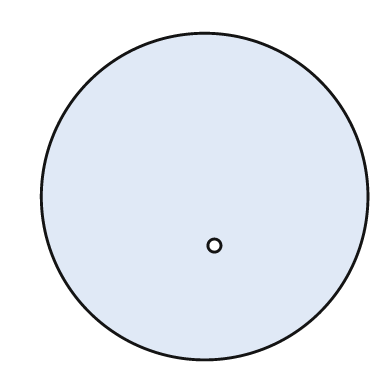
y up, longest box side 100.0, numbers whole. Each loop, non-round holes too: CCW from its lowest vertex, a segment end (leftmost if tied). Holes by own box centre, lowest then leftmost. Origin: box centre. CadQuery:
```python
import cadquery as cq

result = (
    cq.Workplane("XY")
    .moveTo(0.0, 0.0)
    .circle(50.0)
    .moveTo(3.0, -15.0)
    .circle(2.0)
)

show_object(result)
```